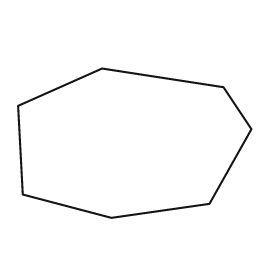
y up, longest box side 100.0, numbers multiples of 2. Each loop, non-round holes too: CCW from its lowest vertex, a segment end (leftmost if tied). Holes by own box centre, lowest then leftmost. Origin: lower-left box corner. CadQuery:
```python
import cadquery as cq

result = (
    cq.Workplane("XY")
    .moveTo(40.0, 0.0)
    .lineTo(82.0, 6.0)
    .lineTo(100.0, 38.0)
    .lineTo(88.0, 56.0)
    .lineTo(36.0, 64.0)
    .lineTo(0.0, 48.0)
    .lineTo(2.0, 10.0)
    .close()
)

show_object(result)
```